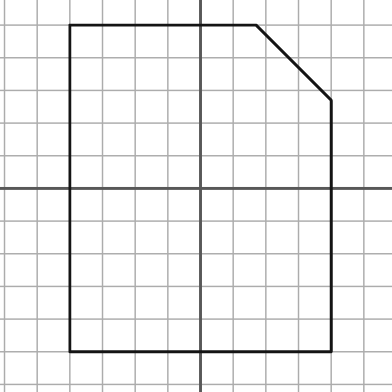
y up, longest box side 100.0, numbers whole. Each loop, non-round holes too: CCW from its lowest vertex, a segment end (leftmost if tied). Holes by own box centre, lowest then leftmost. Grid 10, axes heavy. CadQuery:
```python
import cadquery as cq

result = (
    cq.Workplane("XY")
    .moveTo(-40.0, -50.0)
    .lineTo(40.0, -50.0)
    .lineTo(40.0, 27.0)
    .lineTo(17.0, 50.0)
    .lineTo(-40.0, 50.0)
    .close()
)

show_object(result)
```